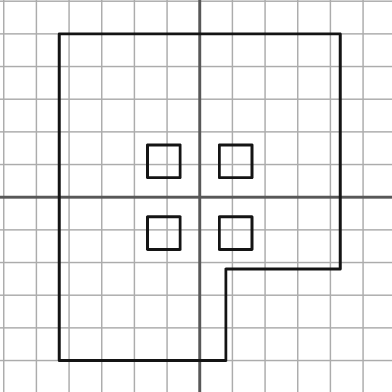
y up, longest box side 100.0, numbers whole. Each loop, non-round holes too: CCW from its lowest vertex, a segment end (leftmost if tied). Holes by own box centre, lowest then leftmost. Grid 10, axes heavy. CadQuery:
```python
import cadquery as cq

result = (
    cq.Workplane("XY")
    .moveTo(-43.0, -50.0)
    .lineTo(8.0, -50.0)
    .lineTo(8.0, -22.0)
    .lineTo(43.0, -22.0)
    .lineTo(43.0, 50.0)
    .lineTo(-43.0, 50.0)
    .close()
    .moveTo(-16.0, -16.0)
    .lineTo(-6.0, -16.0)
    .lineTo(-6.0, -6.0)
    .lineTo(-16.0, -6.0)
    .close()
    .moveTo(6.0, -16.0)
    .lineTo(16.0, -16.0)
    .lineTo(16.0, -6.0)
    .lineTo(6.0, -6.0)
    .close()
    .moveTo(-16.0, 6.0)
    .lineTo(-6.0, 6.0)
    .lineTo(-6.0, 16.0)
    .lineTo(-16.0, 16.0)
    .close()
    .moveTo(6.0, 6.0)
    .lineTo(16.0, 6.0)
    .lineTo(16.0, 16.0)
    .lineTo(6.0, 16.0)
    .close()
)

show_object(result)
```